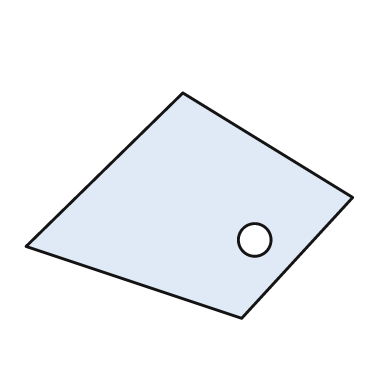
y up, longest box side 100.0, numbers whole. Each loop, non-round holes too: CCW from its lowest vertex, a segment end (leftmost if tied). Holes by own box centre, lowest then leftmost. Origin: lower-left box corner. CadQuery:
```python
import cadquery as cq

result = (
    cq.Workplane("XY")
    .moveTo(66.0, 0.0)
    .lineTo(100.0, 37.0)
    .lineTo(48.0, 69.0)
    .lineTo(0.0, 22.0)
    .close()
    .moveTo(70.0, 24.0)
    .circle(5.0)
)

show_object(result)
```